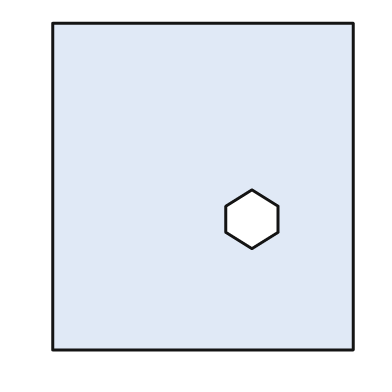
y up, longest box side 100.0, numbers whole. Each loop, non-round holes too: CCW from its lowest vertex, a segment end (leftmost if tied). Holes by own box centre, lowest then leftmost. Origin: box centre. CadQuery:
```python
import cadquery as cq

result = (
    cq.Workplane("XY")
    .moveTo(-46.0, -50.0)
    .lineTo(46.0, -50.0)
    .lineTo(46.0, 50.0)
    .lineTo(-46.0, 50.0)
    .close()
    .moveTo(15.0, -19.0)
    .lineTo(23.0, -14.0)
    .lineTo(23.0, -6.0)
    .lineTo(15.0, -1.0)
    .lineTo(7.0, -6.0)
    .lineTo(7.0, -14.0)
    .close()
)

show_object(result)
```